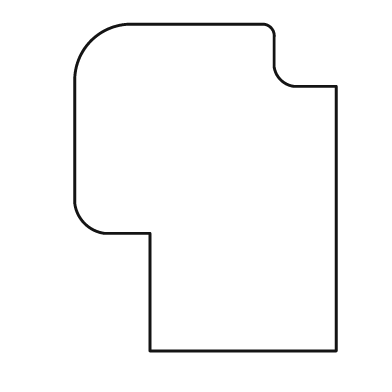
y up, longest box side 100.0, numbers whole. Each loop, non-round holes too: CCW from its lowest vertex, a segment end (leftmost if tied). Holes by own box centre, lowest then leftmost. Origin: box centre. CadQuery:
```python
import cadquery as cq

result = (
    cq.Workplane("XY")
    .moveTo(-17.0, -50.0)
    .lineTo(40.0, -50.0)
    .lineTo(40.0, 31.0)
    .lineTo(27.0, 31.0)
    .threePointArc((23.0, 33.0), (21.0, 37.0))
    .lineTo(21.0, 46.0)
    .threePointArc((20.0, 49.0), (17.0, 50.0))
    .lineTo(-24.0, 50.0)
    .threePointArc((-35.0, 45.0), (-40.0, 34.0))
    .lineTo(-40.0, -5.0)
    .threePointArc((-37.0, -11.0), (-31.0, -14.0))
    .lineTo(-17.0, -14.0)
    .close()
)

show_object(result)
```